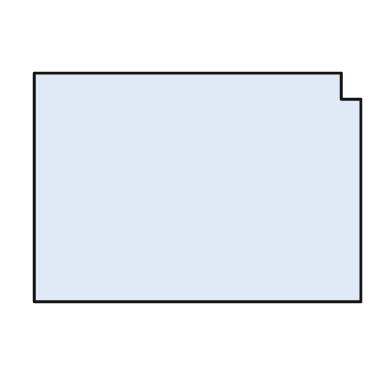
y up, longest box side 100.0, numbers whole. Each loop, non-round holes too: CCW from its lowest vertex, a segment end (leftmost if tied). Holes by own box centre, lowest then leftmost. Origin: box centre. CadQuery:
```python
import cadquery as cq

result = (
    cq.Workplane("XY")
    .moveTo(-50.0, -35.0)
    .lineTo(50.0, -35.0)
    .lineTo(50.0, 27.0)
    .lineTo(44.0, 27.0)
    .lineTo(44.0, 35.0)
    .lineTo(-50.0, 35.0)
    .close()
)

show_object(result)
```